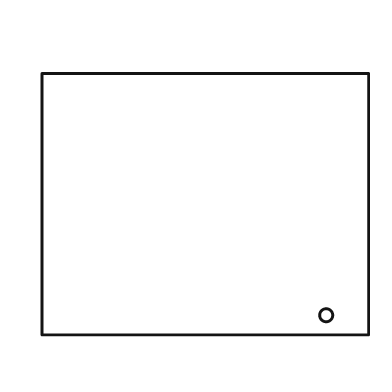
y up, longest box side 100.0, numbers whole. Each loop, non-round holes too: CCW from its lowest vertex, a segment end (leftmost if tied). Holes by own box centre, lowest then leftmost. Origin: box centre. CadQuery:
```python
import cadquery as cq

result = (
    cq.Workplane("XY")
    .moveTo(-50.0, -40.0)
    .lineTo(50.0, -40.0)
    .lineTo(50.0, 40.0)
    .lineTo(-50.0, 40.0)
    .close()
    .moveTo(37.0, -34.0)
    .circle(2.0)
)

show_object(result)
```